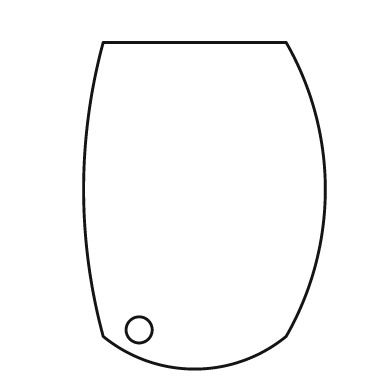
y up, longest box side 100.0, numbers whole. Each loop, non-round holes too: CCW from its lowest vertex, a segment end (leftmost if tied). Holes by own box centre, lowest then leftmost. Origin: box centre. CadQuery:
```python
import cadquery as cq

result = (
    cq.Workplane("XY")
    .moveTo(-31.0, -40.0)
    .threePointArc((-3.0, -50.0), (25.0, -40.0))
    .threePointArc((37.0, 5.0), (25.0, 50.0))
    .lineTo(-31.0, 50.0)
    .threePointArc((-37.0, 5.0), (-31.0, -40.0))
    .close()
    .moveTo(-20.0, -38.0)
    .circle(4.0)
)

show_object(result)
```